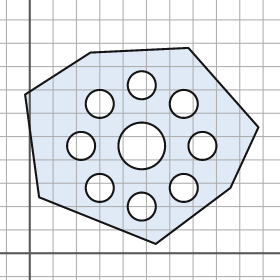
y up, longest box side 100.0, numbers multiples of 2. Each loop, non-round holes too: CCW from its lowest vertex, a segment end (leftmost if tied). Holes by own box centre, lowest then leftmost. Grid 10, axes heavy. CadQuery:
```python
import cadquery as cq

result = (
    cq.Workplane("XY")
    .moveTo(54.0, 4.0)
    .lineTo(86.0, 28.0)
    .lineTo(98.0, 54.0)
    .lineTo(68.0, 88.0)
    .lineTo(26.0, 86.0)
    .lineTo(-2.0, 68.0)
    .lineTo(4.0, 24.0)
    .close()
    .moveTo(48.0, 20.0)
    .circle(6.0)
    .moveTo(30.0, 28.0)
    .circle(6.0)
    .moveTo(66.0, 28.0)
    .circle(6.0)
    .moveTo(22.0, 46.0)
    .circle(6.0)
    .moveTo(48.0, 46.0)
    .circle(10.0)
    .moveTo(74.0, 46.0)
    .circle(6.0)
    .moveTo(30.0, 64.0)
    .circle(6.0)
    .moveTo(66.0, 64.0)
    .circle(6.0)
    .moveTo(48.0, 72.0)
    .circle(6.0)
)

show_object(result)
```